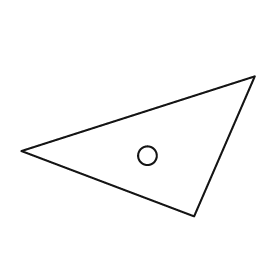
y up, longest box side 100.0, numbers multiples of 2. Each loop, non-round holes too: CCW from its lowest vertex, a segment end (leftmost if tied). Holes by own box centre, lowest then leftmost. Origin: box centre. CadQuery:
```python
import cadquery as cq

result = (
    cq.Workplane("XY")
    .moveTo(24.0, -30.0)
    .lineTo(50.0, 30.0)
    .lineTo(-50.0, -2.0)
    .close()
    .moveTo(4.0, -4.0)
    .circle(4.0)
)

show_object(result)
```